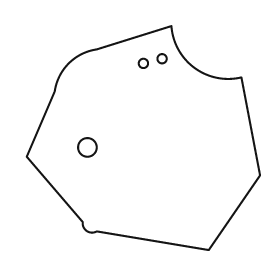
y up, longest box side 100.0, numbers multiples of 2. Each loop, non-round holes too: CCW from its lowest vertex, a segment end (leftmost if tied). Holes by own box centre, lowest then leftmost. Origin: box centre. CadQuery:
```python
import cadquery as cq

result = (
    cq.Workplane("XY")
    .moveTo(28.0, -48.0)
    .lineTo(50.0, -16.0)
    .lineTo(42.0, 26.0)
    .threePointArc((22.0, 30.0), (12.0, 48.0))
    .lineTo(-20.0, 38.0)
    .threePointArc((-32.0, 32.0), (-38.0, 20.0))
    .lineTo(-50.0, -8.0)
    .lineTo(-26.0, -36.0)
    .threePointArc((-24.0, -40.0), (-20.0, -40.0))
    .close()
    .moveTo(-24.0, -4.0)
    .circle(4.0)
    .moveTo(0.0, 32.0)
    .circle(2.0)
    .moveTo(8.0, 34.0)
    .circle(2.0)
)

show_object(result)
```